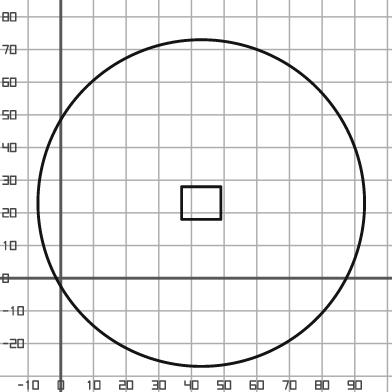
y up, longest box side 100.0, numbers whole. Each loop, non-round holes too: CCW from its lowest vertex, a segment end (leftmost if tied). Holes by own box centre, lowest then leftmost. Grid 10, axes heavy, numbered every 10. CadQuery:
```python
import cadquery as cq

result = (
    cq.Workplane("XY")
    .moveTo(43.0, 23.0)
    .circle(50.0)
    .moveTo(37.0, 18.0)
    .lineTo(49.0, 18.0)
    .lineTo(49.0, 28.0)
    .lineTo(37.0, 28.0)
    .close()
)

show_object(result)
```